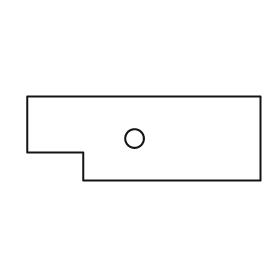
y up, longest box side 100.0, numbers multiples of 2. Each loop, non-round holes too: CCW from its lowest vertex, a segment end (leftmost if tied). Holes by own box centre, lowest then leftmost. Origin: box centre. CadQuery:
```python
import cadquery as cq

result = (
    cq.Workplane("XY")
    .moveTo(-26.0, -18.0)
    .lineTo(50.0, -18.0)
    .lineTo(50.0, 18.0)
    .lineTo(-50.0, 18.0)
    .lineTo(-50.0, -6.0)
    .lineTo(-26.0, -6.0)
    .close()
    .moveTo(-4.0, 0.0)
    .circle(4.0)
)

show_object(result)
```